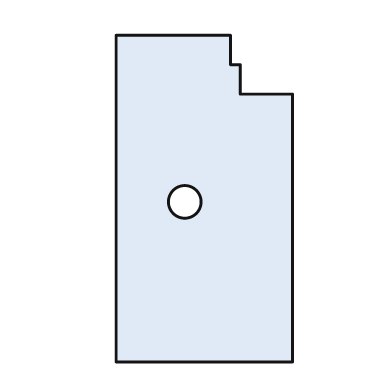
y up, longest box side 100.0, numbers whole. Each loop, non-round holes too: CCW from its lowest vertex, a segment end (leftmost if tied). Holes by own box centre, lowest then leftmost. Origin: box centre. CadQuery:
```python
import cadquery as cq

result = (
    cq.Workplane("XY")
    .moveTo(-27.0, -50.0)
    .lineTo(27.0, -50.0)
    .lineTo(27.0, 32.0)
    .lineTo(11.0, 32.0)
    .lineTo(11.0, 41.0)
    .lineTo(8.0, 41.0)
    .lineTo(8.0, 50.0)
    .lineTo(-27.0, 50.0)
    .close()
    .moveTo(-6.0, -1.0)
    .circle(5.0)
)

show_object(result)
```